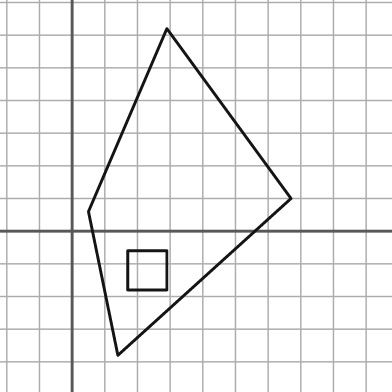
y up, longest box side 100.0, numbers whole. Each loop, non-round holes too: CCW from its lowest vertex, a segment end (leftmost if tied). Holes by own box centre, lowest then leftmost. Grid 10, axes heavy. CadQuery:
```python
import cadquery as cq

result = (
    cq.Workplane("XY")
    .moveTo(14.0, -38.0)
    .lineTo(67.0, 10.0)
    .lineTo(29.0, 62.0)
    .lineTo(5.0, 6.0)
    .close()
    .moveTo(17.0, -18.0)
    .lineTo(29.0, -18.0)
    .lineTo(29.0, -6.0)
    .lineTo(17.0, -6.0)
    .close()
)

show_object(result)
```